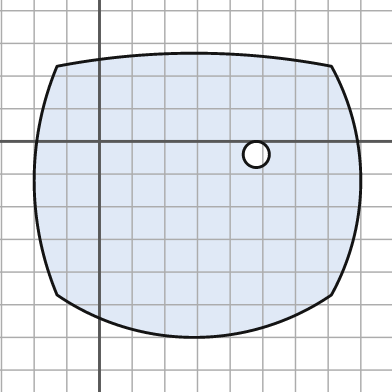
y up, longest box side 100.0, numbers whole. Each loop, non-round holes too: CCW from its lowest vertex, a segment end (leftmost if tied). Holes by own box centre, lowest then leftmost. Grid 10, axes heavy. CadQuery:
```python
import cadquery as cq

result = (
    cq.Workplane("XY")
    .moveTo(-13.0, -47.0)
    .threePointArc((29.0, -60.0), (71.0, -47.0))
    .threePointArc((80.0, -12.0), (71.0, 23.0))
    .threePointArc((29.0, 27.0), (-13.0, 23.0))
    .threePointArc((-20.0, -12.0), (-13.0, -47.0))
    .close()
    .moveTo(48.0, -4.0)
    .circle(4.0)
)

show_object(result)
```